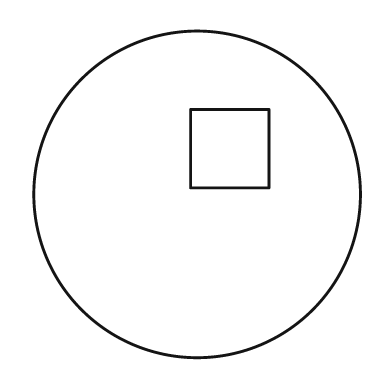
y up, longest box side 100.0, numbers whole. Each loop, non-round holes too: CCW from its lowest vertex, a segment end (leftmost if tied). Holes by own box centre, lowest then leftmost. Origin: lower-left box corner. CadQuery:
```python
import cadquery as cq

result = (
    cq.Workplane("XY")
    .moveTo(50.0, 50.0)
    .circle(50.0)
    .moveTo(48.0, 52.0)
    .lineTo(72.0, 52.0)
    .lineTo(72.0, 76.0)
    .lineTo(48.0, 76.0)
    .close()
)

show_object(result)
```